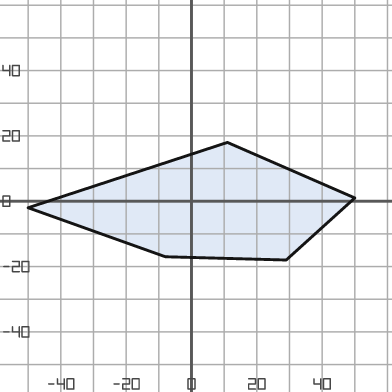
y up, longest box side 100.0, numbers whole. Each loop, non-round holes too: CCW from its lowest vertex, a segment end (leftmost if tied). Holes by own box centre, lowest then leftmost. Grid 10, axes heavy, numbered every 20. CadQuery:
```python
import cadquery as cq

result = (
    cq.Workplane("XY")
    .moveTo(29.0, -18.0)
    .lineTo(50.0, 1.0)
    .lineTo(11.0, 18.0)
    .lineTo(-50.0, -2.0)
    .lineTo(-8.0, -17.0)
    .close()
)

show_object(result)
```